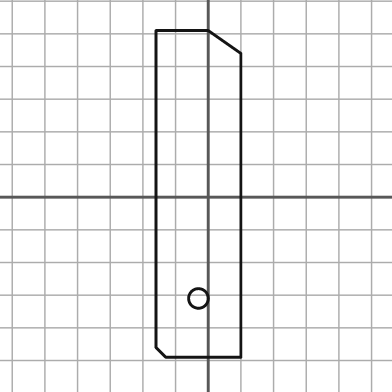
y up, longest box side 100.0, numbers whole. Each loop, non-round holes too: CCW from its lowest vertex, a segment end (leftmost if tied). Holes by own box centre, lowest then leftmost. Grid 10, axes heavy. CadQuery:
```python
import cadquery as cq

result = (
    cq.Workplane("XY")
    .moveTo(-13.0, -49.0)
    .lineTo(10.0, -49.0)
    .lineTo(10.0, 44.0)
    .lineTo(0.0, 51.0)
    .lineTo(-16.0, 51.0)
    .lineTo(-16.0, -46.0)
    .close()
    .moveTo(-3.0, -31.0)
    .circle(3.0)
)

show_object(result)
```